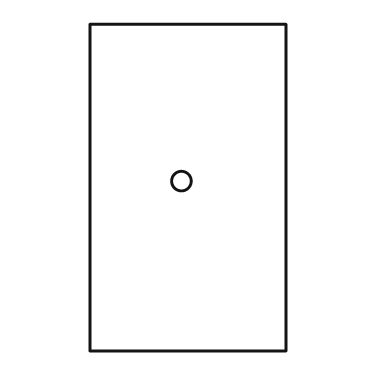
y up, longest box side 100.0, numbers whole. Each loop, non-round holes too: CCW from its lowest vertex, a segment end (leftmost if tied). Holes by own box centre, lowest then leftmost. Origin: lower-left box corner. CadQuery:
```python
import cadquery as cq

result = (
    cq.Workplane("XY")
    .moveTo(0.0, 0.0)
    .lineTo(60.0, 0.0)
    .lineTo(60.0, 100.0)
    .lineTo(0.0, 100.0)
    .close()
    .moveTo(28.0, 52.0)
    .circle(3.0)
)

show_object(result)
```